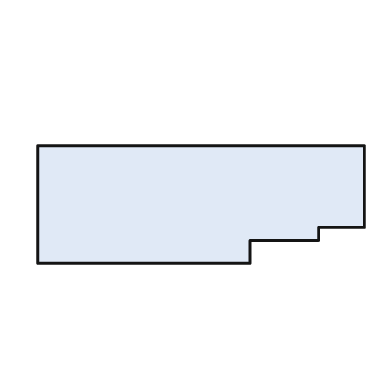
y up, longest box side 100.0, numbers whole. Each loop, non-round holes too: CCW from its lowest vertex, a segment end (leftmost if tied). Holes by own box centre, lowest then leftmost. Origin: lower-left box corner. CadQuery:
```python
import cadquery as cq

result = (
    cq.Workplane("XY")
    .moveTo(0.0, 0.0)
    .lineTo(65.0, 0.0)
    .lineTo(65.0, 7.0)
    .lineTo(86.0, 7.0)
    .lineTo(86.0, 11.0)
    .lineTo(100.0, 11.0)
    .lineTo(100.0, 36.0)
    .lineTo(0.0, 36.0)
    .close()
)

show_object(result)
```